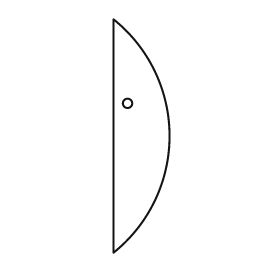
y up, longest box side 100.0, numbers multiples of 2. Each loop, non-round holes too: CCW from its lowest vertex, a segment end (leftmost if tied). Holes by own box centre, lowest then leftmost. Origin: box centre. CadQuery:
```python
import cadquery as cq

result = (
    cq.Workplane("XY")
    .moveTo(-12.0, -50.0)
    .threePointArc((12.0, 0.0), (-12.0, 50.0))
    .close()
    .moveTo(-6.0, 14.0)
    .circle(2.0)
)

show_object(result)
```